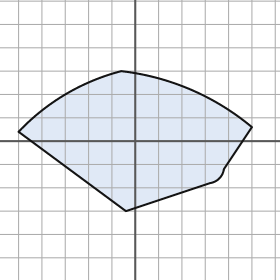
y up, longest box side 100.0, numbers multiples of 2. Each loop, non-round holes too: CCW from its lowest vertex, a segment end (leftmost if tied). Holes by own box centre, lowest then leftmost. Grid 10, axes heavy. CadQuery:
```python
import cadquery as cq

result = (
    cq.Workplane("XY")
    .moveTo(-4.0, -30.0)
    .lineTo(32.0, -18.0)
    .threePointArc((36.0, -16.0), (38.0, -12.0))
    .lineTo(50.0, 6.0)
    .threePointArc((24.0, 22.0), (-6.0, 30.0))
    .threePointArc((-30.0, 20.0), (-50.0, 4.0))
    .close()
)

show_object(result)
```